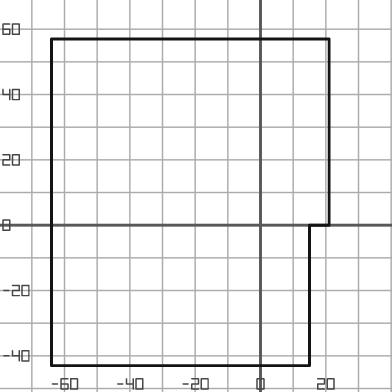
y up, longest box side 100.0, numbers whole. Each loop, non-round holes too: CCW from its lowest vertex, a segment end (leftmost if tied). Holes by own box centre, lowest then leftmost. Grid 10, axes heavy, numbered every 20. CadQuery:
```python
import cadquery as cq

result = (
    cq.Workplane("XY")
    .moveTo(-64.0, -43.0)
    .lineTo(15.0, -43.0)
    .lineTo(15.0, 0.0)
    .lineTo(21.0, 0.0)
    .lineTo(21.0, 57.0)
    .lineTo(-64.0, 57.0)
    .close()
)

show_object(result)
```